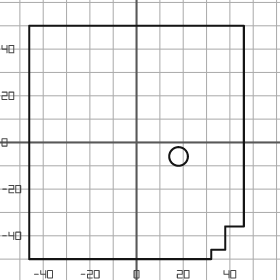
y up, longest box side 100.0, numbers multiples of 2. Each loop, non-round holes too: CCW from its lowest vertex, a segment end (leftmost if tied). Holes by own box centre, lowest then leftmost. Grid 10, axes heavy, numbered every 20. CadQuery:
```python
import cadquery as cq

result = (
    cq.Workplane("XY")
    .moveTo(-46.0, -50.0)
    .lineTo(32.0, -50.0)
    .lineTo(32.0, -46.0)
    .lineTo(38.0, -46.0)
    .lineTo(38.0, -36.0)
    .lineTo(46.0, -36.0)
    .lineTo(46.0, 50.0)
    .lineTo(-46.0, 50.0)
    .close()
    .moveTo(18.0, -6.0)
    .circle(4.0)
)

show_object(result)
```